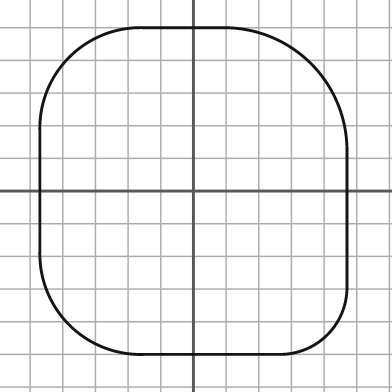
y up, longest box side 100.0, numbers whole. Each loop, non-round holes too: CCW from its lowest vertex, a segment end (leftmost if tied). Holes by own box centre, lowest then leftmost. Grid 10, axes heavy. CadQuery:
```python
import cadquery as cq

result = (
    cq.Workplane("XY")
    .moveTo(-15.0, -50.0)
    .lineTo(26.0, -50.0)
    .threePointArc((41.0, -44.0), (47.0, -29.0))
    .lineTo(47.0, 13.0)
    .threePointArc((36.0, 39.0), (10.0, 50.0))
    .lineTo(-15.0, 50.0)
    .threePointArc((-38.0, 41.0), (-47.0, 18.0))
    .lineTo(-47.0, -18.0)
    .threePointArc((-38.0, -41.0), (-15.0, -50.0))
    .close()
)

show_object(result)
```